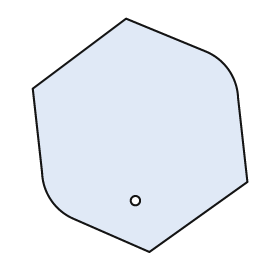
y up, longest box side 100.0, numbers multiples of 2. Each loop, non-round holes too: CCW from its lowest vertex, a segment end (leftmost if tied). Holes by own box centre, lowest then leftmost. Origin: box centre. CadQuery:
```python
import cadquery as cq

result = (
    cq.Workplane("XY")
    .moveTo(4.0, -50.0)
    .lineTo(46.0, -20.0)
    .lineTo(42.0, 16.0)
    .threePointArc((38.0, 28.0), (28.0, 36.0))
    .lineTo(-6.0, 50.0)
    .lineTo(-46.0, 20.0)
    .lineTo(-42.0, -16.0)
    .threePointArc((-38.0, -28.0), (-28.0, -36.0))
    .close()
    .moveTo(-2.0, -28.0)
    .circle(2.0)
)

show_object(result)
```